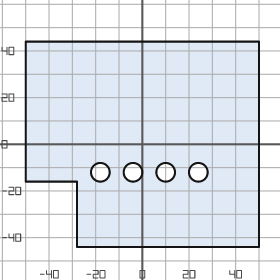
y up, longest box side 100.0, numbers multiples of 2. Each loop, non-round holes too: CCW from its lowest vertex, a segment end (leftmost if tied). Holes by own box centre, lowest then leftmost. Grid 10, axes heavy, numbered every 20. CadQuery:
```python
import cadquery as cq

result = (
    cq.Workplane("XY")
    .moveTo(-28.0, -44.0)
    .lineTo(50.0, -44.0)
    .lineTo(50.0, 44.0)
    .lineTo(-50.0, 44.0)
    .lineTo(-50.0, -16.0)
    .lineTo(-28.0, -16.0)
    .close()
    .moveTo(-18.0, -12.0)
    .circle(4.0)
    .moveTo(-4.0, -12.0)
    .circle(4.0)
    .moveTo(10.0, -12.0)
    .circle(4.0)
    .moveTo(24.0, -12.0)
    .circle(4.0)
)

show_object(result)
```